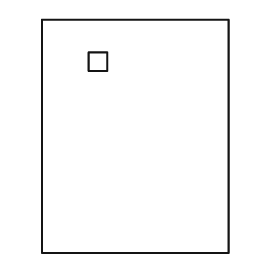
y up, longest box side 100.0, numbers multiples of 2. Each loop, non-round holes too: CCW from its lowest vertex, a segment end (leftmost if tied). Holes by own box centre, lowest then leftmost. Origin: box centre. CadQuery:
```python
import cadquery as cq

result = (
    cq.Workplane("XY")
    .moveTo(-40.0, -50.0)
    .lineTo(40.0, -50.0)
    .lineTo(40.0, 50.0)
    .lineTo(-40.0, 50.0)
    .close()
    .moveTo(-20.0, 28.0)
    .lineTo(-12.0, 28.0)
    .lineTo(-12.0, 36.0)
    .lineTo(-20.0, 36.0)
    .close()
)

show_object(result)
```